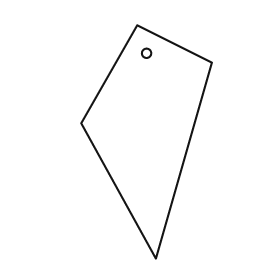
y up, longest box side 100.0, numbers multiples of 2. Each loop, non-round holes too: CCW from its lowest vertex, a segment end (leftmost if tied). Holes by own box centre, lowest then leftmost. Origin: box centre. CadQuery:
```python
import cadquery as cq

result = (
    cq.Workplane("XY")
    .moveTo(4.0, -50.0)
    .lineTo(28.0, 34.0)
    .lineTo(-4.0, 50.0)
    .lineTo(-28.0, 8.0)
    .close()
    .moveTo(0.0, 38.0)
    .circle(2.0)
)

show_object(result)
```